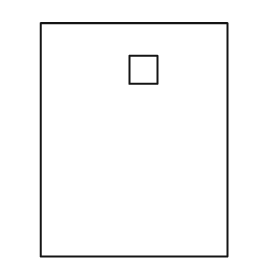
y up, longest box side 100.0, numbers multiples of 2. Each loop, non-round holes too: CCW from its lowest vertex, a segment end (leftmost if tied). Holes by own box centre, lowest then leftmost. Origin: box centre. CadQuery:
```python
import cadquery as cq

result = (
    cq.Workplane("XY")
    .moveTo(-40.0, -50.0)
    .lineTo(40.0, -50.0)
    .lineTo(40.0, 50.0)
    .lineTo(-40.0, 50.0)
    .close()
    .moveTo(-2.0, 24.0)
    .lineTo(10.0, 24.0)
    .lineTo(10.0, 36.0)
    .lineTo(-2.0, 36.0)
    .close()
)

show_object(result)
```